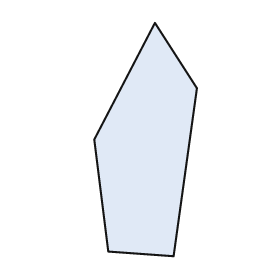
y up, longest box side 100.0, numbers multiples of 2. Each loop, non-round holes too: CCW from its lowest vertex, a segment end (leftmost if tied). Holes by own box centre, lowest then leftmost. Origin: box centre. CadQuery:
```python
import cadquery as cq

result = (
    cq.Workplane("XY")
    .moveTo(12.0, -50.0)
    .lineTo(22.0, 22.0)
    .lineTo(4.0, 50.0)
    .lineTo(-22.0, 0.0)
    .lineTo(-16.0, -48.0)
    .close()
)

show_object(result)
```